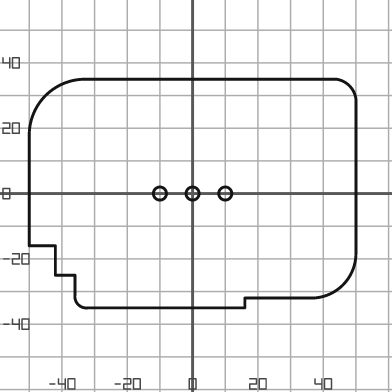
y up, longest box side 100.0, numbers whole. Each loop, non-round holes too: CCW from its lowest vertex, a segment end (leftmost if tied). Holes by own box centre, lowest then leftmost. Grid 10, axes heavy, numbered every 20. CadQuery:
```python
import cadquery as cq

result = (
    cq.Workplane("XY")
    .moveTo(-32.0, -35.0)
    .lineTo(16.0, -35.0)
    .lineTo(16.0, -32.0)
    .lineTo(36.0, -32.0)
    .threePointArc((46.0, -28.0), (50.0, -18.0))
    .lineTo(50.0, 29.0)
    .threePointArc((48.0, 33.0), (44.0, 35.0))
    .lineTo(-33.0, 35.0)
    .threePointArc((-45.0, 30.0), (-50.0, 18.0))
    .lineTo(-50.0, -16.0)
    .lineTo(-42.0, -16.0)
    .lineTo(-42.0, -25.0)
    .lineTo(-36.0, -25.0)
    .lineTo(-36.0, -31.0)
    .threePointArc((-35.0, -34.0), (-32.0, -35.0))
    .close()
    .moveTo(-10.0, 0.0)
    .circle(2.0)
    .moveTo(0.0, 0.0)
    .circle(2.0)
    .moveTo(10.0, 0.0)
    .circle(2.0)
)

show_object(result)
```